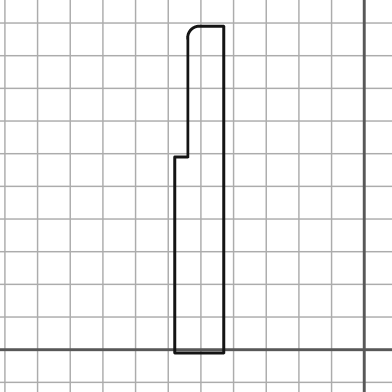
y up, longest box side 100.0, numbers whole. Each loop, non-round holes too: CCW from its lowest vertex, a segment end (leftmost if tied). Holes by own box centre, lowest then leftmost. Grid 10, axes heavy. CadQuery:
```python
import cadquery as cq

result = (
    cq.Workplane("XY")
    .moveTo(-58.0, -1.0)
    .lineTo(-43.0, -1.0)
    .lineTo(-43.0, 99.0)
    .lineTo(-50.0, 99.0)
    .threePointArc((-53.0, 98.0), (-54.0, 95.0))
    .lineTo(-54.0, 59.0)
    .lineTo(-58.0, 59.0)
    .close()
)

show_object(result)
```